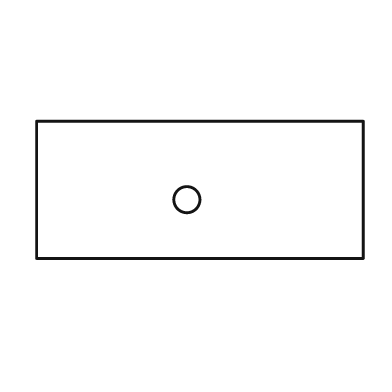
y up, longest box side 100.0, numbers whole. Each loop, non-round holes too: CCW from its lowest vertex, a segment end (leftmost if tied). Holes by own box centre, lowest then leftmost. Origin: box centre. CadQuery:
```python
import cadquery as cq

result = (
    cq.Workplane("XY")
    .moveTo(-50.0, -21.0)
    .lineTo(50.0, -21.0)
    .lineTo(50.0, 21.0)
    .lineTo(-50.0, 21.0)
    .close()
    .moveTo(-4.0, -3.0)
    .circle(4.0)
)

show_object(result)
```